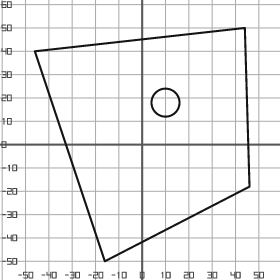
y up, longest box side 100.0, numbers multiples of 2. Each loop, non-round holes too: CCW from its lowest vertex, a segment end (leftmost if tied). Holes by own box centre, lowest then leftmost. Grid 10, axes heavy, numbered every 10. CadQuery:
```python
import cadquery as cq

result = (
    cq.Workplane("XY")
    .moveTo(-16.0, -50.0)
    .lineTo(46.0, -18.0)
    .lineTo(44.0, 50.0)
    .lineTo(-46.0, 40.0)
    .close()
    .moveTo(10.0, 18.0)
    .circle(6.0)
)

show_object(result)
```